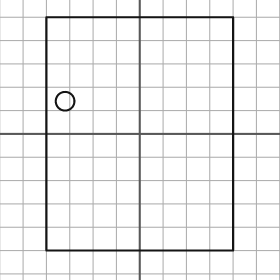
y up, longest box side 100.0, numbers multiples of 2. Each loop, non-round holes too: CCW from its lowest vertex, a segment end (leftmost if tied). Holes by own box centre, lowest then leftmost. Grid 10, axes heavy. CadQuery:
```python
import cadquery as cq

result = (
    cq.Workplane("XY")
    .moveTo(-40.0, -50.0)
    .lineTo(40.0, -50.0)
    .lineTo(40.0, 50.0)
    .lineTo(-40.0, 50.0)
    .close()
    .moveTo(-32.0, 14.0)
    .circle(4.0)
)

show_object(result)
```